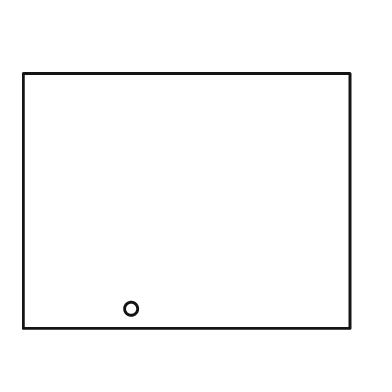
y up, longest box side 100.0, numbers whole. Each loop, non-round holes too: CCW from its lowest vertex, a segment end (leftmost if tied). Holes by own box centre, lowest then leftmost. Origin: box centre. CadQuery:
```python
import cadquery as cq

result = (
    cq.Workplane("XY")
    .moveTo(-50.0, -39.0)
    .lineTo(50.0, -39.0)
    .lineTo(50.0, 39.0)
    .lineTo(-50.0, 39.0)
    .close()
    .moveTo(-17.0, -33.0)
    .circle(2.0)
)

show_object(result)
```